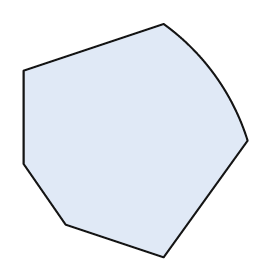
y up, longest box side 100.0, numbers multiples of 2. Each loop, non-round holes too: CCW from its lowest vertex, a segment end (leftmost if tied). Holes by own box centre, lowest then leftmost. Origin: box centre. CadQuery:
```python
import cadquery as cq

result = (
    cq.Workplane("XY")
    .moveTo(12.0, -50.0)
    .lineTo(48.0, 0.0)
    .threePointArc((34.0, 28.0), (12.0, 50.0))
    .lineTo(-48.0, 30.0)
    .lineTo(-48.0, -10.0)
    .lineTo(-30.0, -36.0)
    .close()
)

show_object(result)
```